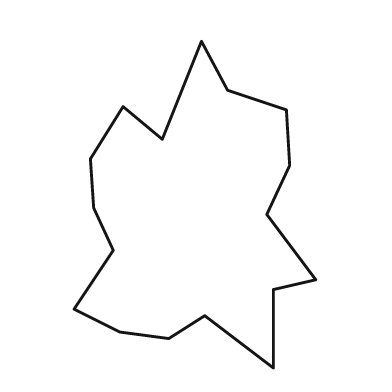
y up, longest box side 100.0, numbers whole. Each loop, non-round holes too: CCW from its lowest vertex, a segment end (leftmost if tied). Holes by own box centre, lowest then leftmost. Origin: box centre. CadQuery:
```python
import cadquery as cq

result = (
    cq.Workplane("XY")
    .moveTo(24.0, -50.0)
    .lineTo(24.0, -26.0)
    .lineTo(37.0, -23.0)
    .lineTo(22.0, -3.0)
    .lineTo(29.0, 12.0)
    .lineTo(28.0, 29.0)
    .lineTo(10.0, 35.0)
    .lineTo(2.0, 50.0)
    .lineTo(-10.0, 20.0)
    .lineTo(-22.0, 30.0)
    .lineTo(-32.0, 14.0)
    .lineTo(-31.0, -1.0)
    .lineTo(-25.0, -14.0)
    .lineTo(-37.0, -32.0)
    .lineTo(-23.0, -39.0)
    .lineTo(-8.0, -41.0)
    .lineTo(3.0, -34.0)
    .close()
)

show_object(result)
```